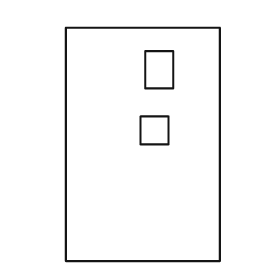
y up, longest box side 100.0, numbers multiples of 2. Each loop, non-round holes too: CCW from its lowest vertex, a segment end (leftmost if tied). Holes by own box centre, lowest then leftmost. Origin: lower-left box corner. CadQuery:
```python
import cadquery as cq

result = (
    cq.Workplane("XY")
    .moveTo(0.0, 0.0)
    .lineTo(66.0, 0.0)
    .lineTo(66.0, 100.0)
    .lineTo(0.0, 100.0)
    .close()
    .moveTo(32.0, 50.0)
    .lineTo(44.0, 50.0)
    .lineTo(44.0, 62.0)
    .lineTo(32.0, 62.0)
    .close()
    .moveTo(34.0, 74.0)
    .lineTo(46.0, 74.0)
    .lineTo(46.0, 90.0)
    .lineTo(34.0, 90.0)
    .close()
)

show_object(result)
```